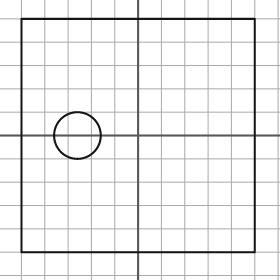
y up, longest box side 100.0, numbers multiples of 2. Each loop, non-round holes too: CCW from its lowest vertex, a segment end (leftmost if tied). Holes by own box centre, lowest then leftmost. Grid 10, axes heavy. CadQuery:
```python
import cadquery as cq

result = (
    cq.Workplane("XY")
    .moveTo(-50.0, -50.0)
    .lineTo(50.0, -50.0)
    .lineTo(50.0, 50.0)
    .lineTo(-50.0, 50.0)
    .close()
    .moveTo(-26.0, 0.0)
    .circle(10.0)
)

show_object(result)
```